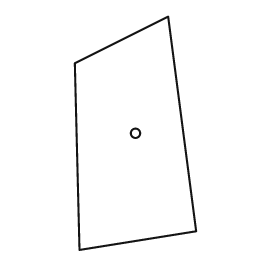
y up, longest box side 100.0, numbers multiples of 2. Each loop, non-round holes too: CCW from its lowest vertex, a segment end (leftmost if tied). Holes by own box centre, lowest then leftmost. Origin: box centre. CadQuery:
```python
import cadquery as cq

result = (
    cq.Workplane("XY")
    .moveTo(-24.0, -50.0)
    .lineTo(26.0, -42.0)
    .lineTo(14.0, 50.0)
    .lineTo(-26.0, 30.0)
    .close()
    .moveTo(0.0, 0.0)
    .circle(2.0)
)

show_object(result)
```